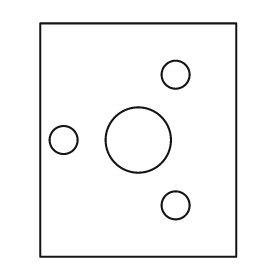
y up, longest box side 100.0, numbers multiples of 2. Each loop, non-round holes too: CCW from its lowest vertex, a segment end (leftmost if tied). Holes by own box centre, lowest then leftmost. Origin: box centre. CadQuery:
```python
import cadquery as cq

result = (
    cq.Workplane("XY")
    .moveTo(-42.0, -50.0)
    .lineTo(42.0, -50.0)
    .lineTo(42.0, 50.0)
    .lineTo(-42.0, 50.0)
    .close()
    .moveTo(16.0, -28.0)
    .circle(6.0)
    .moveTo(-32.0, 0.0)
    .circle(6.0)
    .moveTo(0.0, 0.0)
    .circle(14.0)
    .moveTo(16.0, 28.0)
    .circle(6.0)
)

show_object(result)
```